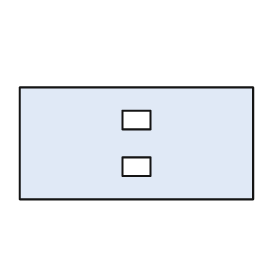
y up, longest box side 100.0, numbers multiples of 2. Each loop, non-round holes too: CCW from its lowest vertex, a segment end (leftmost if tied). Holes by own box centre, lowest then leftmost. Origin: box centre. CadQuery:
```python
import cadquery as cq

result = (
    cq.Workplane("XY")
    .moveTo(-50.0, -24.0)
    .lineTo(50.0, -24.0)
    .lineTo(50.0, 24.0)
    .lineTo(-50.0, 24.0)
    .close()
    .moveTo(-6.0, -14.0)
    .lineTo(6.0, -14.0)
    .lineTo(6.0, -6.0)
    .lineTo(-6.0, -6.0)
    .close()
    .moveTo(-6.0, 6.0)
    .lineTo(6.0, 6.0)
    .lineTo(6.0, 14.0)
    .lineTo(-6.0, 14.0)
    .close()
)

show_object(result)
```